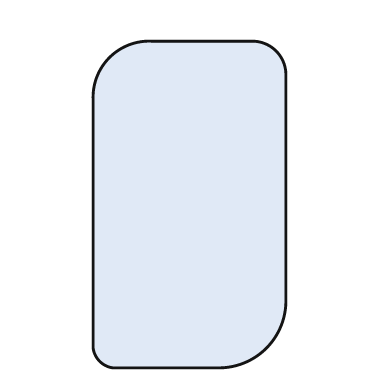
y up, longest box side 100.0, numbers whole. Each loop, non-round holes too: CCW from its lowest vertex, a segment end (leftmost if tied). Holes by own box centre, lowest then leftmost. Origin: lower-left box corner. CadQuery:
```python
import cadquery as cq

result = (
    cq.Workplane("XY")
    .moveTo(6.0, 0.0)
    .lineTo(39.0, 0.0)
    .threePointArc((53.0, 6.0), (59.0, 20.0))
    .lineTo(59.0, 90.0)
    .threePointArc((56.0, 97.0), (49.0, 100.0))
    .lineTo(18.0, 100.0)
    .threePointArc((5.0, 95.0), (0.0, 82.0))
    .lineTo(0.0, 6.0)
    .threePointArc((2.0, 2.0), (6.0, 0.0))
    .close()
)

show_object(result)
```